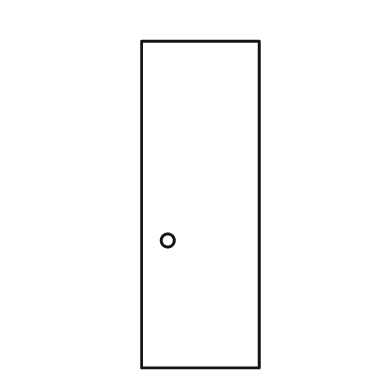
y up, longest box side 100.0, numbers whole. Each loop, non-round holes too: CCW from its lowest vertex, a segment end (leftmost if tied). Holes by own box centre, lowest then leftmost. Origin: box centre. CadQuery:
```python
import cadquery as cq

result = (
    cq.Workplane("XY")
    .moveTo(-18.0, -50.0)
    .lineTo(18.0, -50.0)
    .lineTo(18.0, 50.0)
    .lineTo(-18.0, 50.0)
    .close()
    .moveTo(-10.0, -11.0)
    .circle(2.0)
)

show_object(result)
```